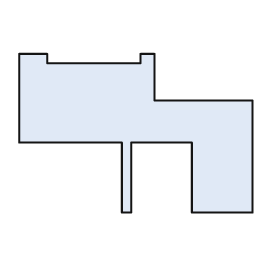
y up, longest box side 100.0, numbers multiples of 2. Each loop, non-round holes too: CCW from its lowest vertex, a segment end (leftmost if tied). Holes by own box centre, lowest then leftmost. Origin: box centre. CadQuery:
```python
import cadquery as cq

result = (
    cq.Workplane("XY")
    .moveTo(-6.0, -34.0)
    .lineTo(-2.0, -34.0)
    .lineTo(-2.0, -4.0)
    .lineTo(24.0, -4.0)
    .lineTo(24.0, -34.0)
    .lineTo(50.0, -34.0)
    .lineTo(50.0, 14.0)
    .lineTo(8.0, 14.0)
    .lineTo(8.0, 34.0)
    .lineTo(2.0, 34.0)
    .lineTo(2.0, 30.0)
    .lineTo(-38.0, 30.0)
    .lineTo(-38.0, 34.0)
    .lineTo(-50.0, 34.0)
    .lineTo(-50.0, -4.0)
    .lineTo(-6.0, -4.0)
    .close()
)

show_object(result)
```